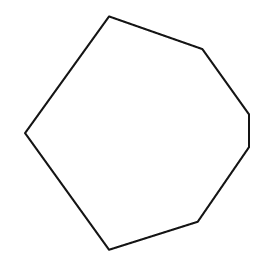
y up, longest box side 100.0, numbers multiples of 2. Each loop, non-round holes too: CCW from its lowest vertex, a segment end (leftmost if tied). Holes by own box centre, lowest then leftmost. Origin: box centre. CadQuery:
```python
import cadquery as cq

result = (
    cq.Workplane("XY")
    .moveTo(-12.0, -50.0)
    .lineTo(26.0, -38.0)
    .lineTo(48.0, -6.0)
    .lineTo(48.0, 8.0)
    .lineTo(28.0, 36.0)
    .lineTo(-12.0, 50.0)
    .lineTo(-48.0, 0.0)
    .close()
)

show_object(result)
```